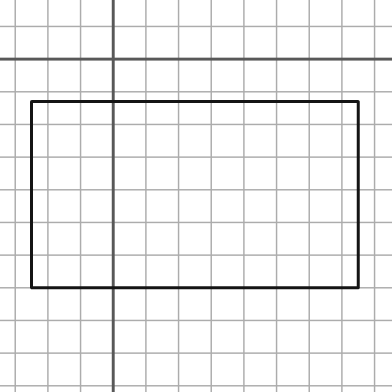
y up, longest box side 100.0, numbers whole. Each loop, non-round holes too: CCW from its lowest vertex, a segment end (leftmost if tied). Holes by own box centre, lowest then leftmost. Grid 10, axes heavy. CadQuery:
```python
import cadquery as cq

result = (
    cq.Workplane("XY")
    .moveTo(-25.0, -70.0)
    .lineTo(75.0, -70.0)
    .lineTo(75.0, -13.0)
    .lineTo(-25.0, -13.0)
    .close()
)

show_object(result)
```